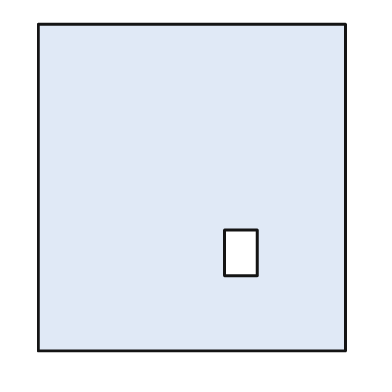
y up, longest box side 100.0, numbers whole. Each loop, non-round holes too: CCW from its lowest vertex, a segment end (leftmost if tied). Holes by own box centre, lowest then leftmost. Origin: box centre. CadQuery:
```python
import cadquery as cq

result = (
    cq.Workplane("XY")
    .moveTo(-47.0, -50.0)
    .lineTo(47.0, -50.0)
    .lineTo(47.0, 50.0)
    .lineTo(-47.0, 50.0)
    .close()
    .moveTo(10.0, -27.0)
    .lineTo(20.0, -27.0)
    .lineTo(20.0, -13.0)
    .lineTo(10.0, -13.0)
    .close()
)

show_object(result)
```